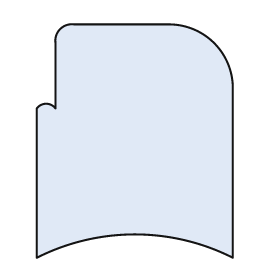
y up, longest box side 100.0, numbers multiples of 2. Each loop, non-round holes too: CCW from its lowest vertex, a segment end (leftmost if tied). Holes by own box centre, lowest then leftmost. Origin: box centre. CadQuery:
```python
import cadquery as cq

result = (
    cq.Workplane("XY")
    .moveTo(-42.0, -50.0)
    .threePointArc((0.0, -40.0), (42.0, -50.0))
    .lineTo(42.0, 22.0)
    .threePointArc((34.0, 42.0), (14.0, 50.0))
    .lineTo(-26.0, 50.0)
    .threePointArc((-32.0, 48.0), (-34.0, 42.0))
    .lineTo(-34.0, 14.0)
    .threePointArc((-38.0, 16.0), (-42.0, 14.0))
    .close()
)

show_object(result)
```